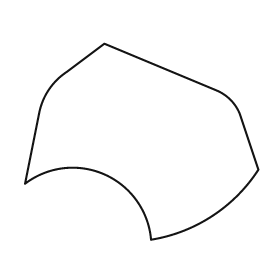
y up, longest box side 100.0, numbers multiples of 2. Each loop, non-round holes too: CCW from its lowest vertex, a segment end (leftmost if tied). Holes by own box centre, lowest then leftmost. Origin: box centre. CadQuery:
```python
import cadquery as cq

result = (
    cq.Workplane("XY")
    .moveTo(4.0, -42.0)
    .threePointArc((30.0, -32.0), (50.0, -12.0))
    .lineTo(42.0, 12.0)
    .threePointArc((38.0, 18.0), (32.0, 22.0))
    .lineTo(-16.0, 42.0)
    .lineTo(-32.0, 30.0)
    .threePointArc((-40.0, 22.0), (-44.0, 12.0))
    .lineTo(-50.0, -18.0)
    .threePointArc((-16.0, -14.0), (4.0, -42.0))
    .close()
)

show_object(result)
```